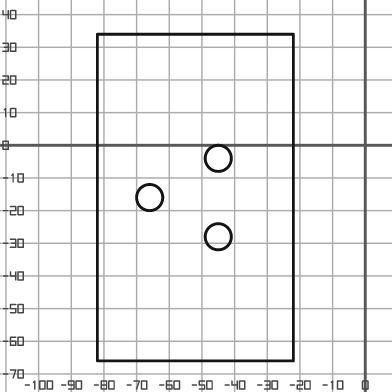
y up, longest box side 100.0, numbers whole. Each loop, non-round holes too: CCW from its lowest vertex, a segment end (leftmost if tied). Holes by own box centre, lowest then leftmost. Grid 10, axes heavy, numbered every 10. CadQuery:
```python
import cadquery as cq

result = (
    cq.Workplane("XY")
    .moveTo(-82.0, -66.0)
    .lineTo(-22.0, -66.0)
    .lineTo(-22.0, 34.0)
    .lineTo(-82.0, 34.0)
    .close()
    .moveTo(-45.0, -28.0)
    .circle(4.0)
    .moveTo(-66.0, -16.0)
    .circle(4.0)
    .moveTo(-45.0, -4.0)
    .circle(4.0)
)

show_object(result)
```